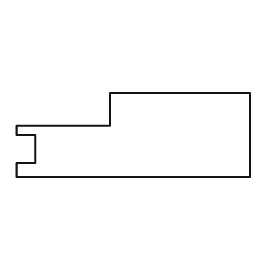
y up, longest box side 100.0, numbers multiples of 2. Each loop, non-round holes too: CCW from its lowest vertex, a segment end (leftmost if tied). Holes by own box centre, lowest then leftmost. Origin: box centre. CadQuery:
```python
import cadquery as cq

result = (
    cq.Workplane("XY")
    .moveTo(-50.0, -18.0)
    .lineTo(50.0, -18.0)
    .lineTo(50.0, 18.0)
    .lineTo(-10.0, 18.0)
    .lineTo(-10.0, 4.0)
    .lineTo(-50.0, 4.0)
    .lineTo(-50.0, 0.0)
    .lineTo(-42.0, 0.0)
    .lineTo(-42.0, -12.0)
    .lineTo(-50.0, -12.0)
    .close()
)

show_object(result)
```